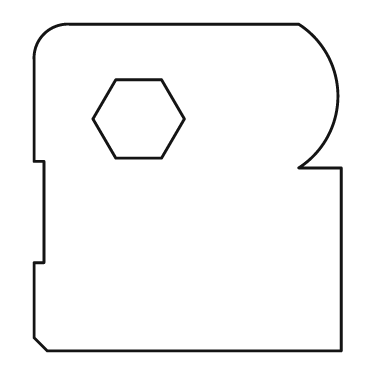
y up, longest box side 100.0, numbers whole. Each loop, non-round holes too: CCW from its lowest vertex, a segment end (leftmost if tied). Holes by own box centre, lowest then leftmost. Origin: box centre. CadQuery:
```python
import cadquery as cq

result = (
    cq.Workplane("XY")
    .moveTo(-43.0, -50.0)
    .lineTo(47.0, -50.0)
    .lineTo(47.0, 6.0)
    .lineTo(34.0, 6.0)
    .threePointArc((46.0, 28.0), (34.0, 50.0))
    .lineTo(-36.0, 50.0)
    .threePointArc((-44.0, 47.0), (-47.0, 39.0))
    .lineTo(-47.0, 8.0)
    .lineTo(-44.0, 8.0)
    .lineTo(-44.0, -23.0)
    .lineTo(-47.0, -23.0)
    .lineTo(-47.0, -46.0)
    .close()
    .moveTo(-22.0, 9.0)
    .lineTo(-8.0, 9.0)
    .lineTo(-1.0, 21.0)
    .lineTo(-8.0, 33.0)
    .lineTo(-22.0, 33.0)
    .lineTo(-29.0, 21.0)
    .close()
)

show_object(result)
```